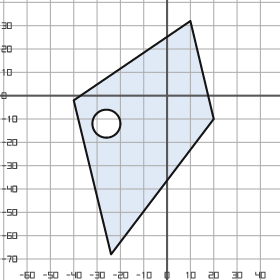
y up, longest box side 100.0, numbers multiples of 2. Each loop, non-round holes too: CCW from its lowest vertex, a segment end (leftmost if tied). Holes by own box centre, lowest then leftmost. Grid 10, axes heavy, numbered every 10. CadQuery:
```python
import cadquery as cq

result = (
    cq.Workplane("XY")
    .moveTo(-24.0, -68.0)
    .lineTo(20.0, -10.0)
    .lineTo(10.0, 32.0)
    .lineTo(-40.0, -2.0)
    .close()
    .moveTo(-26.0, -12.0)
    .circle(6.0)
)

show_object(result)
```